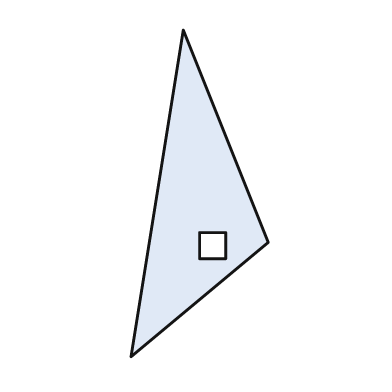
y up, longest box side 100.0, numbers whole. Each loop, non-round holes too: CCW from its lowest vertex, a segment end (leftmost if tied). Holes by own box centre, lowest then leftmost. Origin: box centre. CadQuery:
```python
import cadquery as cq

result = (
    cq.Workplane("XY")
    .moveTo(-21.0, -50.0)
    .lineTo(21.0, -15.0)
    .lineTo(-5.0, 50.0)
    .close()
    .moveTo(0.0, -20.0)
    .lineTo(8.0, -20.0)
    .lineTo(8.0, -12.0)
    .lineTo(0.0, -12.0)
    .close()
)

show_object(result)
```